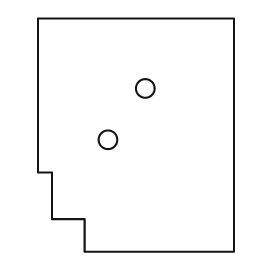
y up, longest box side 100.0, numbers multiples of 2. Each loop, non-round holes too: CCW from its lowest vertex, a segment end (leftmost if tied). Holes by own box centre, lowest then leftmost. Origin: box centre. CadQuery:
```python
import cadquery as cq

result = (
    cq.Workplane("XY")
    .moveTo(-22.0, -50.0)
    .lineTo(42.0, -50.0)
    .lineTo(42.0, 50.0)
    .lineTo(-42.0, 50.0)
    .lineTo(-42.0, -16.0)
    .lineTo(-36.0, -16.0)
    .lineTo(-36.0, -36.0)
    .lineTo(-22.0, -36.0)
    .close()
    .moveTo(-12.0, -2.0)
    .circle(4.0)
    .moveTo(4.0, 20.0)
    .circle(4.0)
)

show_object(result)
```